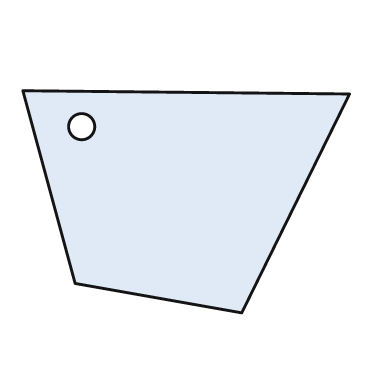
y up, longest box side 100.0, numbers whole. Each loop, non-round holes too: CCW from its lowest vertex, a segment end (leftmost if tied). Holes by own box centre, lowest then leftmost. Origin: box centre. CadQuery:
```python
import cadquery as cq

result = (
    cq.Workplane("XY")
    .moveTo(17.0, -34.0)
    .lineTo(50.0, 33.0)
    .lineTo(-50.0, 34.0)
    .lineTo(-34.0, -25.0)
    .close()
    .moveTo(-32.0, 23.0)
    .circle(4.0)
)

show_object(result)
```